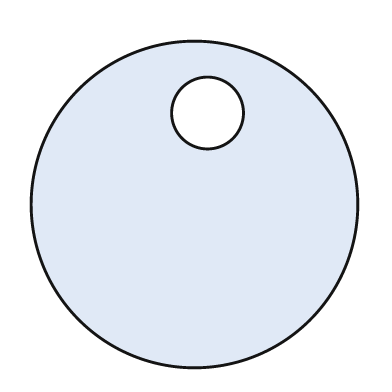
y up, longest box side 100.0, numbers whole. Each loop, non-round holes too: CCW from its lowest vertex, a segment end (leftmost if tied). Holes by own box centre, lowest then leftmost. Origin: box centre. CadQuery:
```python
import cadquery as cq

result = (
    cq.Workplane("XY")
    .moveTo(0.0, 0.0)
    .circle(50.0)
    .moveTo(4.0, 28.0)
    .circle(11.0)
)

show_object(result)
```